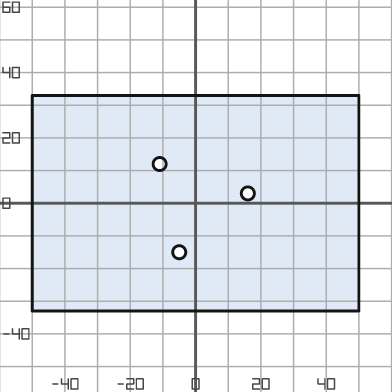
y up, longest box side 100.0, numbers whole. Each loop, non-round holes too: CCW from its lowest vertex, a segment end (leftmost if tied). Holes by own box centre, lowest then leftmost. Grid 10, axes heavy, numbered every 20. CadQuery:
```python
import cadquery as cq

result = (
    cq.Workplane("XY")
    .moveTo(-50.0, -33.0)
    .lineTo(50.0, -33.0)
    .lineTo(50.0, 33.0)
    .lineTo(-50.0, 33.0)
    .close()
    .moveTo(-5.0, -15.0)
    .circle(2.0)
    .moveTo(16.0, 3.0)
    .circle(2.0)
    .moveTo(-11.0, 12.0)
    .circle(2.0)
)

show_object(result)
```